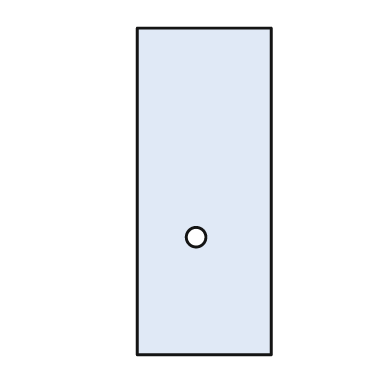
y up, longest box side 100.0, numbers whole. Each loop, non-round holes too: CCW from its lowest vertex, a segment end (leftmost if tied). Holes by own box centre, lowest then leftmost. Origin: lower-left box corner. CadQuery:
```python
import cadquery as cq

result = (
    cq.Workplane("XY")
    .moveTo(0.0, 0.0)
    .lineTo(41.0, 0.0)
    .lineTo(41.0, 100.0)
    .lineTo(0.0, 100.0)
    .close()
    .moveTo(18.0, 36.0)
    .circle(3.0)
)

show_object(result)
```